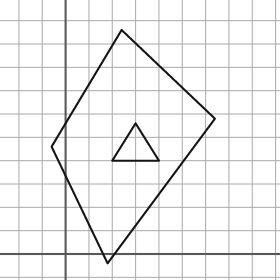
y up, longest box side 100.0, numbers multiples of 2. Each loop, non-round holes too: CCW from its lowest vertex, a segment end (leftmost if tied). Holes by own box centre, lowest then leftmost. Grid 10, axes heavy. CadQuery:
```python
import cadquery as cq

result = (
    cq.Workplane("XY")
    .moveTo(18.0, -4.0)
    .lineTo(64.0, 58.0)
    .lineTo(24.0, 96.0)
    .lineTo(-6.0, 46.0)
    .close()
    .moveTo(20.0, 40.0)
    .lineTo(40.0, 40.0)
    .lineTo(30.0, 56.0)
    .close()
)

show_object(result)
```